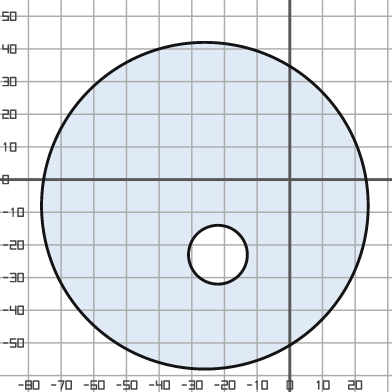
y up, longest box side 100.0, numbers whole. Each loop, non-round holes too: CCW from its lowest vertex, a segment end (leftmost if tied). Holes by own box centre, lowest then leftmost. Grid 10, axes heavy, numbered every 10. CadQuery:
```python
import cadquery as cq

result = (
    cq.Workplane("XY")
    .moveTo(-26.0, -8.0)
    .circle(50.0)
    .moveTo(-22.0, -23.0)
    .circle(9.0)
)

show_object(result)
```